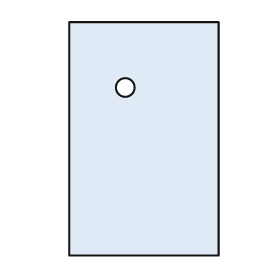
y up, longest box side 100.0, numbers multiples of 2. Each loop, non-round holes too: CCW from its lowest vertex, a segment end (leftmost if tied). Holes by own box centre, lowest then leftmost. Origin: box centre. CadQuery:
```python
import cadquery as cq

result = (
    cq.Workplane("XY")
    .moveTo(-32.0, -50.0)
    .lineTo(32.0, -50.0)
    .lineTo(32.0, 50.0)
    .lineTo(-32.0, 50.0)
    .close()
    .moveTo(-8.0, 22.0)
    .circle(4.0)
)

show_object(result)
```